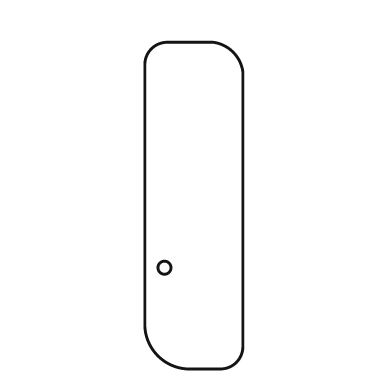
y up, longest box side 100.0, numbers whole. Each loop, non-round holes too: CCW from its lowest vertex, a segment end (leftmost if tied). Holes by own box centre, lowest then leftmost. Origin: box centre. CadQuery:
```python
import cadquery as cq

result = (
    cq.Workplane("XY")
    .moveTo(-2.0, -50.0)
    .lineTo(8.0, -50.0)
    .threePointArc((13.0, -48.0), (15.0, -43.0))
    .lineTo(15.0, 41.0)
    .threePointArc((12.0, 47.0), (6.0, 50.0))
    .lineTo(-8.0, 50.0)
    .threePointArc((-13.0, 48.0), (-15.0, 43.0))
    .lineTo(-15.0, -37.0)
    .threePointArc((-11.0, -46.0), (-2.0, -50.0))
    .close()
    .moveTo(-9.0, -19.0)
    .circle(2.0)
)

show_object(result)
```